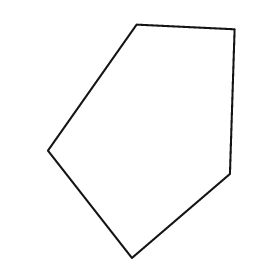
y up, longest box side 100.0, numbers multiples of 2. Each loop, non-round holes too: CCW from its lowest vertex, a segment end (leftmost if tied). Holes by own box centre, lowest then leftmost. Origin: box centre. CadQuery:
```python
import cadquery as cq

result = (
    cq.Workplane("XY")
    .moveTo(-4.0, -50.0)
    .lineTo(38.0, -14.0)
    .lineTo(40.0, 48.0)
    .lineTo(-2.0, 50.0)
    .lineTo(-40.0, -4.0)
    .close()
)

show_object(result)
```